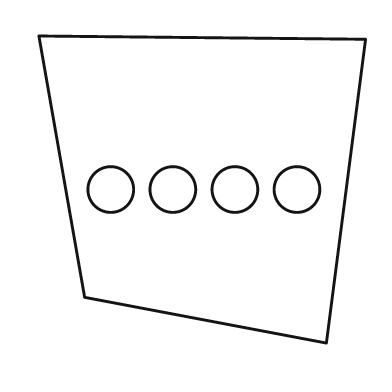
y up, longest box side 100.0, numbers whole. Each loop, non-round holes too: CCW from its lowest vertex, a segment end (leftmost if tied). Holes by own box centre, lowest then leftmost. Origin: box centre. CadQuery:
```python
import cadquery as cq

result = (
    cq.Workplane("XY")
    .moveTo(38.0, -47.0)
    .lineTo(50.0, 46.0)
    .lineTo(-50.0, 47.0)
    .lineTo(-36.0, -33.0)
    .close()
    .moveTo(-28.0, 0.0)
    .circle(7.0)
    .moveTo(-9.0, 0.0)
    .circle(7.0)
    .moveTo(10.0, 0.0)
    .circle(7.0)
    .moveTo(29.0, 0.0)
    .circle(7.0)
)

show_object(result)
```